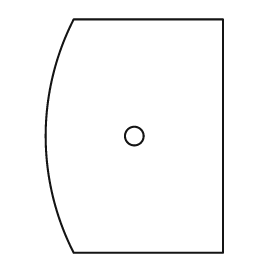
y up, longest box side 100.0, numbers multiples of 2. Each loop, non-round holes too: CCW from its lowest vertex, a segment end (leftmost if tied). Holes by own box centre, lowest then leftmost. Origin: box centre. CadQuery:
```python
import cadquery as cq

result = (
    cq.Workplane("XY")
    .moveTo(-26.0, -50.0)
    .lineTo(38.0, -50.0)
    .lineTo(38.0, 50.0)
    .lineTo(-26.0, 50.0)
    .threePointArc((-38.0, 0.0), (-26.0, -50.0))
    .close()
    .moveTo(0.0, 0.0)
    .circle(4.0)
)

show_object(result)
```